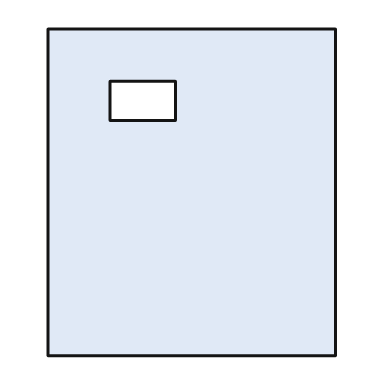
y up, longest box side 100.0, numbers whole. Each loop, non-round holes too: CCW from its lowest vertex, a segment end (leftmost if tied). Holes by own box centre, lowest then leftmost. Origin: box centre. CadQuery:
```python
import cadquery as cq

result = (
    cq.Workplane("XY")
    .moveTo(-44.0, -50.0)
    .lineTo(44.0, -50.0)
    .lineTo(44.0, 50.0)
    .lineTo(-44.0, 50.0)
    .close()
    .moveTo(-25.0, 22.0)
    .lineTo(-5.0, 22.0)
    .lineTo(-5.0, 34.0)
    .lineTo(-25.0, 34.0)
    .close()
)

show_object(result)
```